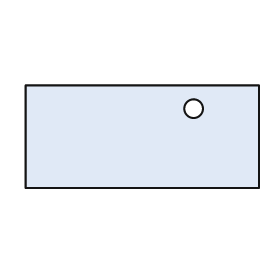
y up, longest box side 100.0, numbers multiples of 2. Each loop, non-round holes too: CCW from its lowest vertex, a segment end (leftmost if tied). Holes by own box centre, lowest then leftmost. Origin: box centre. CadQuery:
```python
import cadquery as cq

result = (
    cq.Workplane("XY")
    .moveTo(-50.0, -22.0)
    .lineTo(50.0, -22.0)
    .lineTo(50.0, 22.0)
    .lineTo(-50.0, 22.0)
    .close()
    .moveTo(22.0, 12.0)
    .circle(4.0)
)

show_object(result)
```